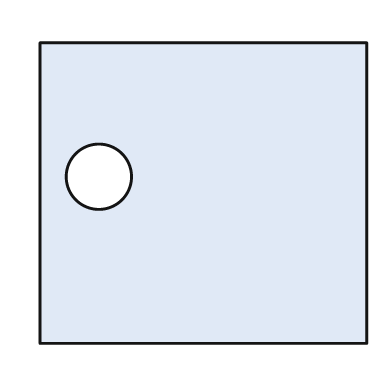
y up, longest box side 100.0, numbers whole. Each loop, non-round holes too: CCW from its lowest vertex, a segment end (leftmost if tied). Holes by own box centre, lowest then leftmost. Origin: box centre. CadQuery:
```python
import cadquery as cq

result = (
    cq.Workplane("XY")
    .moveTo(-50.0, -46.0)
    .lineTo(50.0, -46.0)
    .lineTo(50.0, 46.0)
    .lineTo(-50.0, 46.0)
    .close()
    .moveTo(-32.0, 5.0)
    .circle(10.0)
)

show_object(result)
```